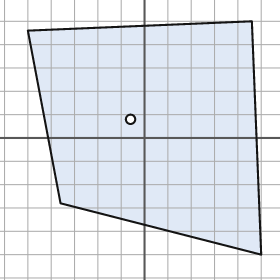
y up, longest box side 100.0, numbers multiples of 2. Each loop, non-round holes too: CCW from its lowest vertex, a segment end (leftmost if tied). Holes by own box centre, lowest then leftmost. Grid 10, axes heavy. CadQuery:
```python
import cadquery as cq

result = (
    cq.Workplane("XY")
    .moveTo(50.0, -50.0)
    .lineTo(46.0, 50.0)
    .lineTo(-50.0, 46.0)
    .lineTo(-36.0, -28.0)
    .close()
    .moveTo(-6.0, 8.0)
    .circle(2.0)
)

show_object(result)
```